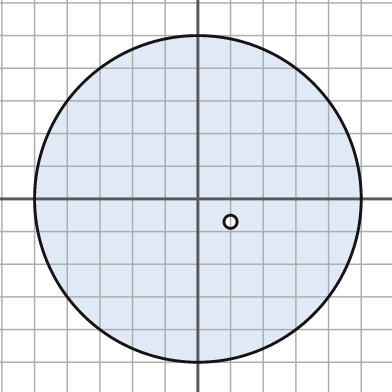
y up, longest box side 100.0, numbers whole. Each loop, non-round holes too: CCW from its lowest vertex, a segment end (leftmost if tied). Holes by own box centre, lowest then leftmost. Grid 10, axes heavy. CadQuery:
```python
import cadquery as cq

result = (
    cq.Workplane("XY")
    .moveTo(0.0, 0.0)
    .circle(50.0)
    .moveTo(10.0, -7.0)
    .circle(2.0)
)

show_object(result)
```